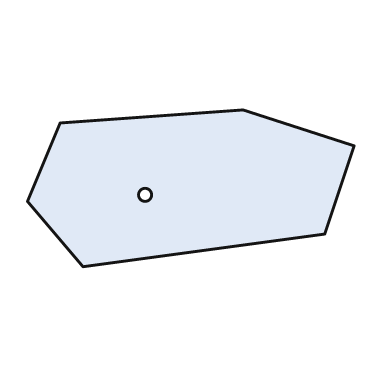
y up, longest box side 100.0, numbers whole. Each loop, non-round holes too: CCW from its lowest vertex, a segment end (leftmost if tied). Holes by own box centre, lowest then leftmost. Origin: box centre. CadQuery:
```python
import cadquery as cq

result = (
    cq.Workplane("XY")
    .moveTo(-33.0, -24.0)
    .lineTo(41.0, -14.0)
    .lineTo(50.0, 13.0)
    .lineTo(16.0, 24.0)
    .lineTo(-40.0, 20.0)
    .lineTo(-50.0, -4.0)
    .close()
    .moveTo(-14.0, -2.0)
    .circle(2.0)
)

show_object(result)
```